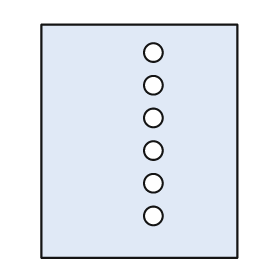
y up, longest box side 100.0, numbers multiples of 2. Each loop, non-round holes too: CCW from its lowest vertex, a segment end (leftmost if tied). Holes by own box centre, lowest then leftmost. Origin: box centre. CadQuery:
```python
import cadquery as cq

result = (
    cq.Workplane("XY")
    .moveTo(-42.0, -50.0)
    .lineTo(42.0, -50.0)
    .lineTo(42.0, 50.0)
    .lineTo(-42.0, 50.0)
    .close()
    .moveTo(6.0, -32.0)
    .circle(4.0)
    .moveTo(6.0, -18.0)
    .circle(4.0)
    .moveTo(6.0, -4.0)
    .circle(4.0)
    .moveTo(6.0, 10.0)
    .circle(4.0)
    .moveTo(6.0, 24.0)
    .circle(4.0)
    .moveTo(6.0, 38.0)
    .circle(4.0)
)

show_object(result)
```